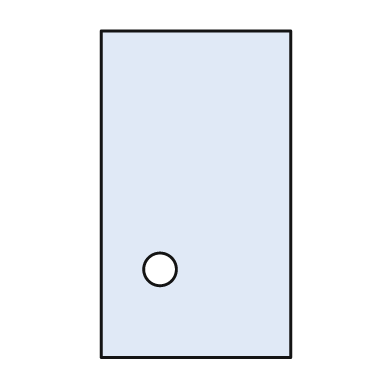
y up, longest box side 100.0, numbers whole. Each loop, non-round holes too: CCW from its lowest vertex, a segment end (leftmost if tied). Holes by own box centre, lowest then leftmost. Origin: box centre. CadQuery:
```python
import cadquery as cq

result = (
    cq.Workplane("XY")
    .moveTo(-29.0, -50.0)
    .lineTo(29.0, -50.0)
    .lineTo(29.0, 50.0)
    .lineTo(-29.0, 50.0)
    .close()
    .moveTo(-11.0, -23.0)
    .circle(5.0)
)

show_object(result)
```